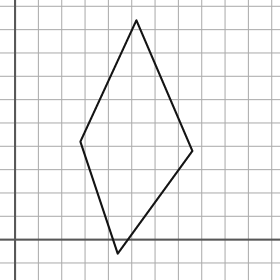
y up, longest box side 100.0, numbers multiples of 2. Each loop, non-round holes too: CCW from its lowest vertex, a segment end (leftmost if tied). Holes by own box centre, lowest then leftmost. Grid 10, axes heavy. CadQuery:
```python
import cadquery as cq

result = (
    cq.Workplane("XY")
    .moveTo(44.0, -6.0)
    .lineTo(76.0, 38.0)
    .lineTo(52.0, 94.0)
    .lineTo(28.0, 42.0)
    .close()
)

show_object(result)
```